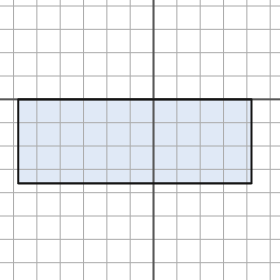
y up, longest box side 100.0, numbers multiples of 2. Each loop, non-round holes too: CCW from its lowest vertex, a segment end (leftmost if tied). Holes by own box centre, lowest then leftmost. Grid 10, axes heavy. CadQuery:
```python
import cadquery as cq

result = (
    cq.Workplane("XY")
    .moveTo(-58.0, -36.0)
    .lineTo(42.0, -36.0)
    .lineTo(42.0, 0.0)
    .lineTo(-58.0, 0.0)
    .close()
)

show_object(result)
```